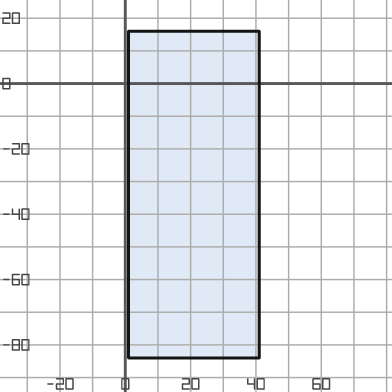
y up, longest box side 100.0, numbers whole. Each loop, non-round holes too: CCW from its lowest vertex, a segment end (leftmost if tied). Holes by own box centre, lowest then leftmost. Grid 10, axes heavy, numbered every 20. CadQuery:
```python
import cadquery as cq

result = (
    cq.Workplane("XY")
    .moveTo(1.0, -84.0)
    .lineTo(41.0, -84.0)
    .lineTo(41.0, 16.0)
    .lineTo(1.0, 16.0)
    .close()
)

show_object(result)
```